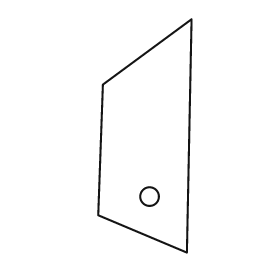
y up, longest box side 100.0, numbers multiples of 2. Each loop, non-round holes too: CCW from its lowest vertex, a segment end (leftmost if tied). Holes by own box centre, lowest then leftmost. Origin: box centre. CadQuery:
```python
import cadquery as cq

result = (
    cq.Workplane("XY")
    .moveTo(18.0, -50.0)
    .lineTo(20.0, 50.0)
    .lineTo(-18.0, 22.0)
    .lineTo(-20.0, -34.0)
    .close()
    .moveTo(2.0, -26.0)
    .circle(4.0)
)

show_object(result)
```